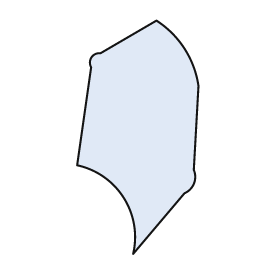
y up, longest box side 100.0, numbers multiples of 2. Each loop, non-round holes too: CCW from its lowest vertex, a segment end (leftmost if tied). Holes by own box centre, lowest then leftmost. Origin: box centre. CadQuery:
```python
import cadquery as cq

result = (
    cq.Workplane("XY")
    .moveTo(-2.0, -50.0)
    .lineTo(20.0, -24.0)
    .threePointArc((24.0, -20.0), (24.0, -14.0))
    .lineTo(26.0, 22.0)
    .threePointArc((20.0, 38.0), (8.0, 50.0))
    .lineTo(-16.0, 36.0)
    .threePointArc((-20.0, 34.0), (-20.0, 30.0))
    .lineTo(-26.0, -12.0)
    .threePointArc((-6.0, -26.0), (-2.0, -50.0))
    .close()
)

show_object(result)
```